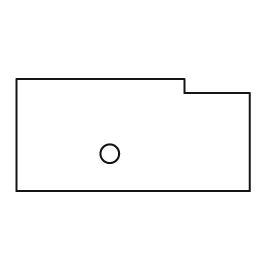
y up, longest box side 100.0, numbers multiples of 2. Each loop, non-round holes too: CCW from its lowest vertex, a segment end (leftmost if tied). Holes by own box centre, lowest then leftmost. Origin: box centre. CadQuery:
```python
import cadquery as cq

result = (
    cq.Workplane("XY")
    .moveTo(-50.0, -24.0)
    .lineTo(50.0, -24.0)
    .lineTo(50.0, 18.0)
    .lineTo(22.0, 18.0)
    .lineTo(22.0, 24.0)
    .lineTo(-50.0, 24.0)
    .close()
    .moveTo(-10.0, -8.0)
    .circle(4.0)
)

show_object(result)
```